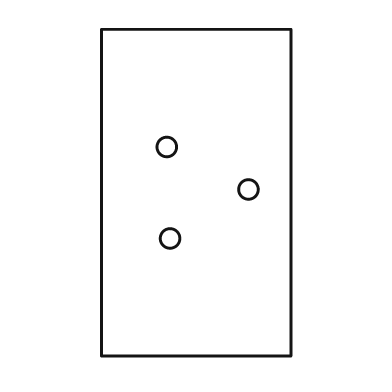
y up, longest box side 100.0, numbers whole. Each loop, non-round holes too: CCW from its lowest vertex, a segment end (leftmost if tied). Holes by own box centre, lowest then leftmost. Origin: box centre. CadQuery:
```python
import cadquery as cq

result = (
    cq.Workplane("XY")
    .moveTo(-29.0, -50.0)
    .lineTo(29.0, -50.0)
    .lineTo(29.0, 50.0)
    .lineTo(-29.0, 50.0)
    .close()
    .moveTo(-8.0, -14.0)
    .circle(3.0)
    .moveTo(16.0, 1.0)
    .circle(3.0)
    .moveTo(-9.0, 14.0)
    .circle(3.0)
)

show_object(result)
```